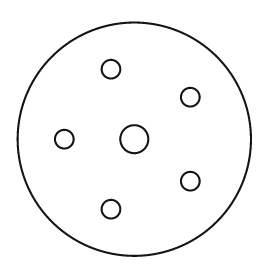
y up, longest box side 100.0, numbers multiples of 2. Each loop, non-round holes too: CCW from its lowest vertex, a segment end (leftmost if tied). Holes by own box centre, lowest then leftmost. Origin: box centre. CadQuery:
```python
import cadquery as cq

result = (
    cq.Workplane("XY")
    .moveTo(0.0, 0.0)
    .circle(50.0)
    .moveTo(-10.0, -30.0)
    .circle(4.0)
    .moveTo(24.0, -18.0)
    .circle(4.0)
    .moveTo(-30.0, 0.0)
    .circle(4.0)
    .moveTo(0.0, 0.0)
    .circle(6.0)
    .moveTo(24.0, 18.0)
    .circle(4.0)
    .moveTo(-10.0, 30.0)
    .circle(4.0)
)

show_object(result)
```